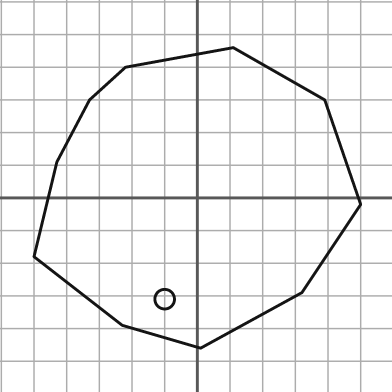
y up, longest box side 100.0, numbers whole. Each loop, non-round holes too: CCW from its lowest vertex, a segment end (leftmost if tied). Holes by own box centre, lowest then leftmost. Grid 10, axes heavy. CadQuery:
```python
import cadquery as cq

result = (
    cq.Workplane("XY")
    .moveTo(1.0, -46.0)
    .lineTo(32.0, -29.0)
    .lineTo(50.0, -2.0)
    .lineTo(39.0, 30.0)
    .lineTo(11.0, 46.0)
    .lineTo(-22.0, 40.0)
    .lineTo(-33.0, 30.0)
    .lineTo(-43.0, 11.0)
    .lineTo(-50.0, -18.0)
    .lineTo(-23.0, -39.0)
    .close()
    .moveTo(-10.0, -31.0)
    .circle(3.0)
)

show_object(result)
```